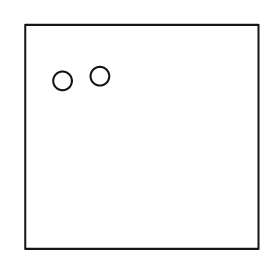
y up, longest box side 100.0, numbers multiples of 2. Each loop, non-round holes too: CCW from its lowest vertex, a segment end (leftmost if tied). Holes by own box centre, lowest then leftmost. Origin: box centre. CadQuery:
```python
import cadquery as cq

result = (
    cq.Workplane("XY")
    .moveTo(-50.0, -48.0)
    .lineTo(50.0, -48.0)
    .lineTo(50.0, 48.0)
    .lineTo(-50.0, 48.0)
    .close()
    .moveTo(-34.0, 24.0)
    .circle(4.0)
    .moveTo(-18.0, 26.0)
    .circle(4.0)
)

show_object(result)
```